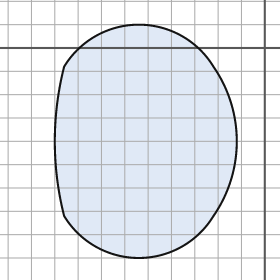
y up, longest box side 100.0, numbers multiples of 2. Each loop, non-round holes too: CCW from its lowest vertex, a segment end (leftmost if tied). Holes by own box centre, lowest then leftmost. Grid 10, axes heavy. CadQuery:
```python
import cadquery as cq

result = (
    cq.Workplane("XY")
    .moveTo(-86.0, -72.0)
    .threePointArc((-54.0, -90.0), (-22.0, -72.0))
    .threePointArc((-12.0, -40.0), (-22.0, -8.0))
    .threePointArc((-54.0, 10.0), (-86.0, -8.0))
    .threePointArc((-90.0, -40.0), (-86.0, -72.0))
    .close()
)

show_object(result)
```